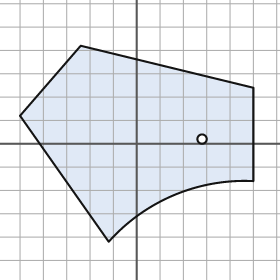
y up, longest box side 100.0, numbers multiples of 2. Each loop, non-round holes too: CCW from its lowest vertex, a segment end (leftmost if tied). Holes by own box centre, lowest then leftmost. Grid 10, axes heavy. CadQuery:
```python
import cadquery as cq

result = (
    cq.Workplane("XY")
    .moveTo(-12.0, -42.0)
    .threePointArc((16.0, -22.0), (50.0, -16.0))
    .lineTo(50.0, 24.0)
    .lineTo(-24.0, 42.0)
    .lineTo(-50.0, 12.0)
    .close()
    .moveTo(28.0, 2.0)
    .circle(2.0)
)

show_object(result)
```